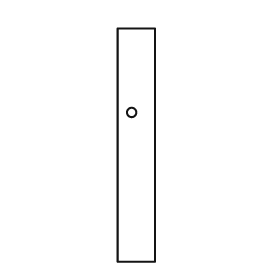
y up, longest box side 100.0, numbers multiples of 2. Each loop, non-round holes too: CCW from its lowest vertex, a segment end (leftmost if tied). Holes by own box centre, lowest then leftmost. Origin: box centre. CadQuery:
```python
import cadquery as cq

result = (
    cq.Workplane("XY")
    .moveTo(-8.0, -50.0)
    .lineTo(8.0, -50.0)
    .lineTo(8.0, 50.0)
    .lineTo(-8.0, 50.0)
    .close()
    .moveTo(-2.0, 14.0)
    .circle(2.0)
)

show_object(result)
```